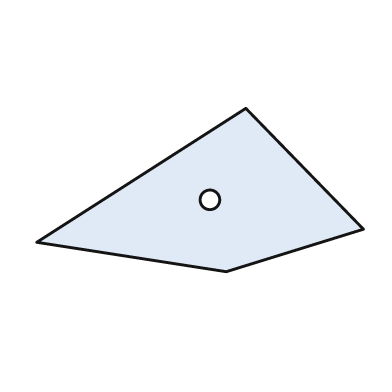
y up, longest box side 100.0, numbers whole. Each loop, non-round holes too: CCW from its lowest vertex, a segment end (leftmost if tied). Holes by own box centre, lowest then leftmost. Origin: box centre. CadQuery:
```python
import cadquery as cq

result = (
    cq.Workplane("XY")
    .moveTo(8.0, -25.0)
    .lineTo(50.0, -12.0)
    .lineTo(14.0, 25.0)
    .lineTo(-50.0, -16.0)
    .close()
    .moveTo(3.0, -3.0)
    .circle(3.0)
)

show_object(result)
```